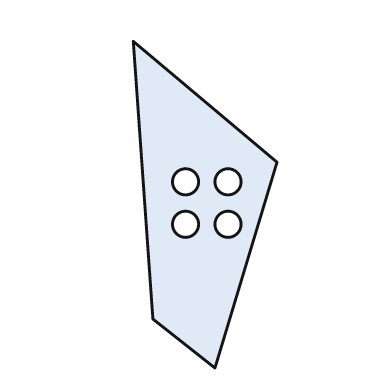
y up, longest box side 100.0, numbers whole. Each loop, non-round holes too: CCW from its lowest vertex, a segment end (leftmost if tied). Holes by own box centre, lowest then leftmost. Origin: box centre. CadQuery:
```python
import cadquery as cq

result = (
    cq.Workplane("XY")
    .moveTo(3.0, -50.0)
    .lineTo(22.0, 13.0)
    .lineTo(-22.0, 50.0)
    .lineTo(-16.0, -35.0)
    .close()
    .moveTo(-6.0, -6.0)
    .circle(4.0)
    .moveTo(7.0, -6.0)
    .circle(4.0)
    .moveTo(-6.0, 7.0)
    .circle(4.0)
    .moveTo(7.0, 7.0)
    .circle(4.0)
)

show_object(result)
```